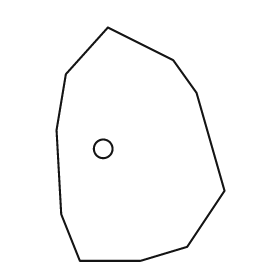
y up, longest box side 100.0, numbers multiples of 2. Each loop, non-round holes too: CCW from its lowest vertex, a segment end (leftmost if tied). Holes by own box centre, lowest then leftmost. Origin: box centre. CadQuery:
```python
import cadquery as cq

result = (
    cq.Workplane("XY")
    .moveTo(-26.0, -50.0)
    .lineTo(0.0, -50.0)
    .lineTo(20.0, -44.0)
    .lineTo(36.0, -20.0)
    .lineTo(24.0, 22.0)
    .lineTo(14.0, 36.0)
    .lineTo(-14.0, 50.0)
    .lineTo(-32.0, 30.0)
    .lineTo(-36.0, 6.0)
    .lineTo(-34.0, -30.0)
    .close()
    .moveTo(-16.0, -2.0)
    .circle(4.0)
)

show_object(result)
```